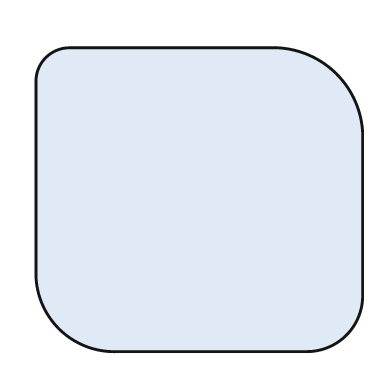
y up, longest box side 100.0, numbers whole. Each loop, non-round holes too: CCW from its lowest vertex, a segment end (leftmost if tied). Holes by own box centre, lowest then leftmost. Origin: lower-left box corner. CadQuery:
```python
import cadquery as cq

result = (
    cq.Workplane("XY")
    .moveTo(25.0, 0.0)
    .lineTo(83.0, 0.0)
    .threePointArc((95.0, 5.0), (100.0, 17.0))
    .lineTo(100.0, 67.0)
    .threePointArc((92.0, 85.0), (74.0, 93.0))
    .lineTo(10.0, 93.0)
    .threePointArc((3.0, 90.0), (0.0, 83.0))
    .lineTo(0.0, 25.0)
    .threePointArc((7.0, 7.0), (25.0, 0.0))
    .close()
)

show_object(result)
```